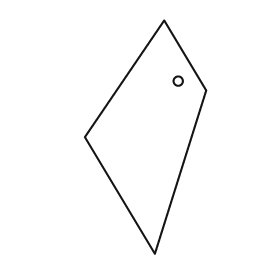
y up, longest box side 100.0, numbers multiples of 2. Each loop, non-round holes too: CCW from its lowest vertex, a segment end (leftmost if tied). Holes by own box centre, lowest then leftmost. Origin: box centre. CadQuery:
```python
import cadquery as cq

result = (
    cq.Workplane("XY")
    .moveTo(4.0, -50.0)
    .lineTo(26.0, 20.0)
    .lineTo(8.0, 50.0)
    .lineTo(-26.0, 0.0)
    .close()
    .moveTo(14.0, 24.0)
    .circle(2.0)
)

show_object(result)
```